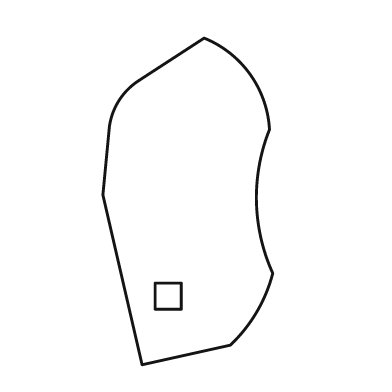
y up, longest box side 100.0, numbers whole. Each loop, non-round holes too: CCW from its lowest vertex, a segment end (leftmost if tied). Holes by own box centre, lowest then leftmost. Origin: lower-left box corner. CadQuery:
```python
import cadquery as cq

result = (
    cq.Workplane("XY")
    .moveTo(12.0, 0.0)
    .lineTo(39.0, 6.0)
    .threePointArc((47.0, 16.0), (52.0, 28.0))
    .threePointArc((47.0, 50.0), (51.0, 72.0))
    .threePointArc((45.0, 89.0), (31.0, 100.0))
    .lineTo(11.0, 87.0)
    .threePointArc((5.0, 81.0), (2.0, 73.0))
    .lineTo(0.0, 52.0)
    .close()
    .moveTo(16.0, 17.0)
    .lineTo(24.0, 17.0)
    .lineTo(24.0, 25.0)
    .lineTo(16.0, 25.0)
    .close()
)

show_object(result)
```